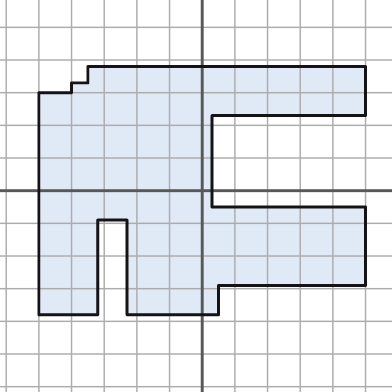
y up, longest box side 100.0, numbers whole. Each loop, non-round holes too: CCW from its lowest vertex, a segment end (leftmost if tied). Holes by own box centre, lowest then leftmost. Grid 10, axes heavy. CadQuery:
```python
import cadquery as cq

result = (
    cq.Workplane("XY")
    .moveTo(-50.0, -38.0)
    .lineTo(-32.0, -38.0)
    .lineTo(-32.0, -9.0)
    .lineTo(-23.0, -9.0)
    .lineTo(-23.0, -38.0)
    .lineTo(5.0, -38.0)
    .lineTo(5.0, -29.0)
    .lineTo(50.0, -29.0)
    .lineTo(50.0, -5.0)
    .lineTo(3.0, -5.0)
    .lineTo(3.0, 23.0)
    .lineTo(50.0, 23.0)
    .lineTo(50.0, 38.0)
    .lineTo(-35.0, 38.0)
    .lineTo(-35.0, 33.0)
    .lineTo(-40.0, 33.0)
    .lineTo(-40.0, 30.0)
    .lineTo(-50.0, 30.0)
    .close()
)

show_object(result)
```